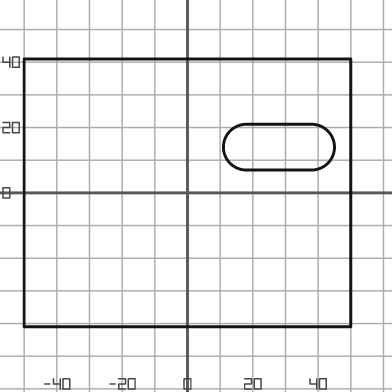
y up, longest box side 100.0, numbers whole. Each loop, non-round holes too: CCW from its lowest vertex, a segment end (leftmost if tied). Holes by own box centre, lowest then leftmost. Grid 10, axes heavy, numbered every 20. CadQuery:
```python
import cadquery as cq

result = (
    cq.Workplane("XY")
    .moveTo(-50.0, -41.0)
    .lineTo(50.0, -41.0)
    .lineTo(50.0, 41.0)
    .lineTo(-50.0, 41.0)
    .close()
    .moveTo(18.0, 7.0)
    .lineTo(38.0, 7.0)
    .threePointArc((45.0, 14.0), (38.0, 21.0))
    .lineTo(18.0, 21.0)
    .threePointArc((11.0, 14.0), (18.0, 7.0))
    .close()
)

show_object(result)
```